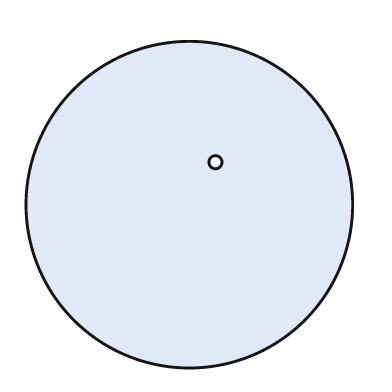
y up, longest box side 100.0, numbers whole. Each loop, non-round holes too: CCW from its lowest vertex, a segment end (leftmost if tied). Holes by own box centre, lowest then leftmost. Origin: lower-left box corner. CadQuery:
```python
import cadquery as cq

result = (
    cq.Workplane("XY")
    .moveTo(50.0, 50.0)
    .circle(50.0)
    .moveTo(58.0, 63.0)
    .circle(2.0)
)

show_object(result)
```